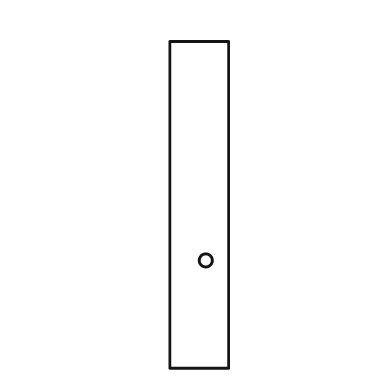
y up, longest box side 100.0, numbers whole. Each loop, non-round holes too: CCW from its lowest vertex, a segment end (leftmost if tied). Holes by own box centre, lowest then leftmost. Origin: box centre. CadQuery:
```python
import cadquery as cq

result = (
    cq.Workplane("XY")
    .moveTo(-9.0, -50.0)
    .lineTo(9.0, -50.0)
    .lineTo(9.0, 50.0)
    .lineTo(-9.0, 50.0)
    .close()
    .moveTo(2.0, -17.0)
    .circle(2.0)
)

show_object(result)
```